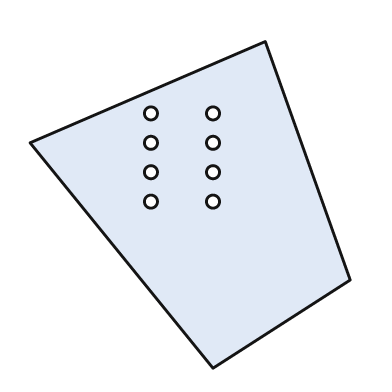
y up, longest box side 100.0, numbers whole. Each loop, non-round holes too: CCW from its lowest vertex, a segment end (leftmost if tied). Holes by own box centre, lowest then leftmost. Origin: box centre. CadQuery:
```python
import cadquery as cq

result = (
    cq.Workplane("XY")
    .moveTo(7.0, -50.0)
    .lineTo(49.0, -23.0)
    .lineTo(23.0, 50.0)
    .lineTo(-49.0, 19.0)
    .close()
    .moveTo(-12.0, 1.0)
    .circle(2.0)
    .moveTo(7.0, 1.0)
    .circle(2.0)
    .moveTo(-12.0, 10.0)
    .circle(2.0)
    .moveTo(7.0, 10.0)
    .circle(2.0)
    .moveTo(-12.0, 19.0)
    .circle(2.0)
    .moveTo(7.0, 19.0)
    .circle(2.0)
    .moveTo(-12.0, 28.0)
    .circle(2.0)
    .moveTo(7.0, 28.0)
    .circle(2.0)
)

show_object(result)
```